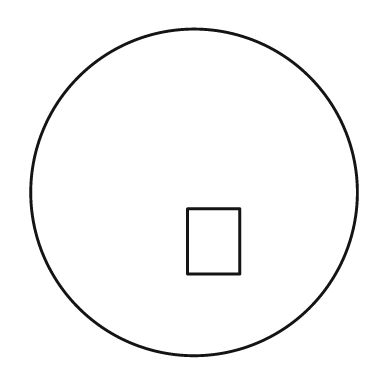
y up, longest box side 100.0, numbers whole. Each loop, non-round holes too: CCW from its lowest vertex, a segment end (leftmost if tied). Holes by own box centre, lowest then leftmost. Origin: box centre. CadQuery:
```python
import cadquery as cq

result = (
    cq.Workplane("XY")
    .moveTo(0.0, 0.0)
    .circle(50.0)
    .moveTo(-2.0, -25.0)
    .lineTo(14.0, -25.0)
    .lineTo(14.0, -5.0)
    .lineTo(-2.0, -5.0)
    .close()
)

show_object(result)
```